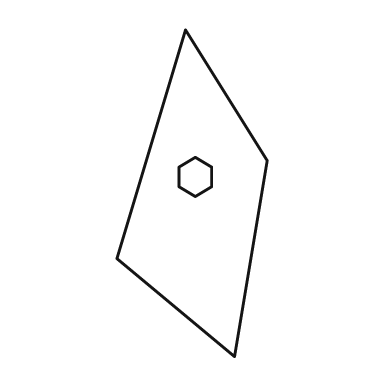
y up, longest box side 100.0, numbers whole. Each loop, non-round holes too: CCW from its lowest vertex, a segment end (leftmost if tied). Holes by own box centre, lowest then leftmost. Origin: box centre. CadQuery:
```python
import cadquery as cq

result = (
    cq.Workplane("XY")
    .moveTo(13.0, -50.0)
    .lineTo(23.0, 10.0)
    .lineTo(-2.0, 50.0)
    .lineTo(-23.0, -20.0)
    .close()
    .moveTo(1.0, -1.0)
    .lineTo(6.0, 2.0)
    .lineTo(6.0, 8.0)
    .lineTo(1.0, 11.0)
    .lineTo(-4.0, 8.0)
    .lineTo(-4.0, 2.0)
    .close()
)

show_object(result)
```